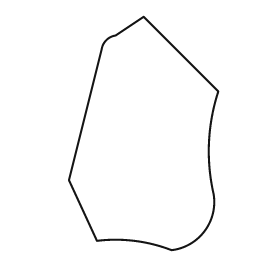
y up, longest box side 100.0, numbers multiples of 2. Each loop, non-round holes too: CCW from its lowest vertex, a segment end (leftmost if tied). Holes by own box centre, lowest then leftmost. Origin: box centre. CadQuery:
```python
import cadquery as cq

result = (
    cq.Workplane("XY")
    .moveTo(12.0, -50.0)
    .threePointArc((26.0, -42.0), (30.0, -26.0))
    .threePointArc((28.0, -4.0), (32.0, 18.0))
    .lineTo(0.0, 50.0)
    .lineTo(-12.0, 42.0)
    .threePointArc((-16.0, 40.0), (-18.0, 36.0))
    .lineTo(-32.0, -20.0)
    .lineTo(-20.0, -46.0)
    .threePointArc((-4.0, -46.0), (12.0, -50.0))
    .close()
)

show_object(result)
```